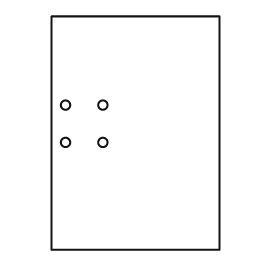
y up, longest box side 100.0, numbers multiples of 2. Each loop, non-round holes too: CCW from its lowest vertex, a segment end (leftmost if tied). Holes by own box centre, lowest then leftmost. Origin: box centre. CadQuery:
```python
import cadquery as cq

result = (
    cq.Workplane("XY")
    .moveTo(-36.0, -50.0)
    .lineTo(36.0, -50.0)
    .lineTo(36.0, 50.0)
    .lineTo(-36.0, 50.0)
    .close()
    .moveTo(-30.0, -4.0)
    .circle(2.0)
    .moveTo(-14.0, -4.0)
    .circle(2.0)
    .moveTo(-30.0, 12.0)
    .circle(2.0)
    .moveTo(-14.0, 12.0)
    .circle(2.0)
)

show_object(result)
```